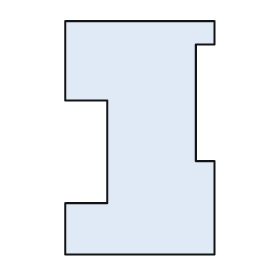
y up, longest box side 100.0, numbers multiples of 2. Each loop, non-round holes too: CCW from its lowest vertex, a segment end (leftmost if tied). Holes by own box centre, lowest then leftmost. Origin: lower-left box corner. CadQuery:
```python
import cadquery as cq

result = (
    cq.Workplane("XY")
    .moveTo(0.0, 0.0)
    .lineTo(64.0, 0.0)
    .lineTo(64.0, 40.0)
    .lineTo(56.0, 40.0)
    .lineTo(56.0, 90.0)
    .lineTo(64.0, 90.0)
    .lineTo(64.0, 100.0)
    .lineTo(0.0, 100.0)
    .lineTo(0.0, 66.0)
    .lineTo(18.0, 66.0)
    .lineTo(18.0, 22.0)
    .lineTo(0.0, 22.0)
    .close()
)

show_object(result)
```